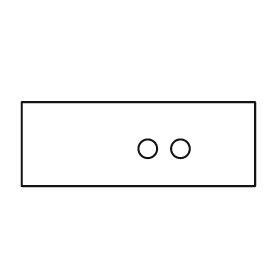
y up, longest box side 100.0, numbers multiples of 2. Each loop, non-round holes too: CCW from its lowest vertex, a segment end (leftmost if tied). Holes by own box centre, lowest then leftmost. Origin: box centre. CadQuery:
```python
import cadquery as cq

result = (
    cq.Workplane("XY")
    .moveTo(-50.0, -18.0)
    .lineTo(50.0, -18.0)
    .lineTo(50.0, 18.0)
    .lineTo(-50.0, 18.0)
    .close()
    .moveTo(4.0, -2.0)
    .circle(4.0)
    .moveTo(18.0, -2.0)
    .circle(4.0)
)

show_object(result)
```